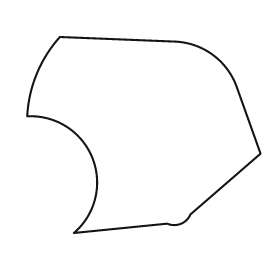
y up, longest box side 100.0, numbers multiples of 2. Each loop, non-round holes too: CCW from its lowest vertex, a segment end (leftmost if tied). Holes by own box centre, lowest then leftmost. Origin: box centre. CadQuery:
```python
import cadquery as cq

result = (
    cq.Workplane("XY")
    .moveTo(-30.0, -42.0)
    .lineTo(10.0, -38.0)
    .threePointArc((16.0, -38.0), (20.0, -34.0))
    .lineTo(50.0, -8.0)
    .lineTo(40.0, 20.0)
    .threePointArc((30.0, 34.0), (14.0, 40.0))
    .lineTo(-36.0, 42.0)
    .threePointArc((-46.0, 26.0), (-50.0, 8.0))
    .threePointArc((-22.0, -10.0), (-30.0, -42.0))
    .close()
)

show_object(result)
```